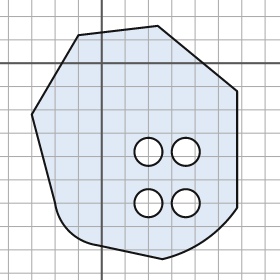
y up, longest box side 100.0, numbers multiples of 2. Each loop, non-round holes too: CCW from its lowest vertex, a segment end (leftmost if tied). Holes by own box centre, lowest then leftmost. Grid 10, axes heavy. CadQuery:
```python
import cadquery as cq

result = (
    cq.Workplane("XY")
    .moveTo(26.0, -84.0)
    .threePointArc((44.0, -76.0), (58.0, -62.0))
    .lineTo(58.0, -12.0)
    .lineTo(24.0, 16.0)
    .lineTo(-10.0, 12.0)
    .lineTo(-30.0, -22.0)
    .lineTo(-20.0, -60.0)
    .threePointArc((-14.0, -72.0), (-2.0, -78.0))
    .close()
    .moveTo(20.0, -60.0)
    .circle(6.0)
    .moveTo(36.0, -60.0)
    .circle(6.0)
    .moveTo(20.0, -38.0)
    .circle(6.0)
    .moveTo(36.0, -38.0)
    .circle(6.0)
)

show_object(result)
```